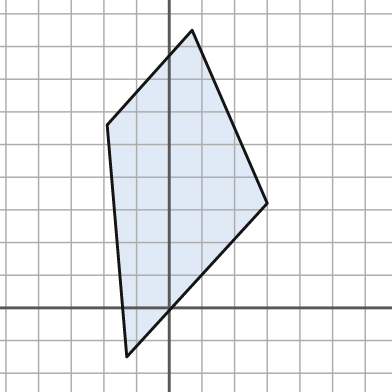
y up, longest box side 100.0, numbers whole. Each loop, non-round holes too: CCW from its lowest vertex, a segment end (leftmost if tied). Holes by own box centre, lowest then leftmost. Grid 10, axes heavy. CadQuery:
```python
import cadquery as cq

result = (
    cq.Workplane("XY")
    .moveTo(-13.0, -15.0)
    .lineTo(30.0, 32.0)
    .lineTo(7.0, 85.0)
    .lineTo(-19.0, 56.0)
    .close()
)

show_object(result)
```